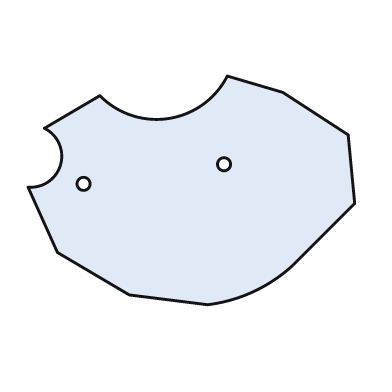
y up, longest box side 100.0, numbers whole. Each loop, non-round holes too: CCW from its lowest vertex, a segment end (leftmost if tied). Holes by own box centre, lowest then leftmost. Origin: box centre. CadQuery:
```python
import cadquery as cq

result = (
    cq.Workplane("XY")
    .moveTo(5.0, -35.0)
    .threePointArc((19.0, -31.0), (31.0, -23.0))
    .lineTo(50.0, -4.0)
    .lineTo(48.0, 17.0)
    .lineTo(28.0, 30.0)
    .lineTo(11.0, 35.0)
    .threePointArc((-7.0, 22.0), (-28.0, 29.0))
    .lineTo(-45.0, 19.0)
    .threePointArc((-40.0, 8.0), (-50.0, 1.0))
    .lineTo(-41.0, -19.0)
    .lineTo(-19.0, -32.0)
    .close()
    .moveTo(-33.0, 2.0)
    .circle(2.0)
    .moveTo(10.0, 8.0)
    .circle(2.0)
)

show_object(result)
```